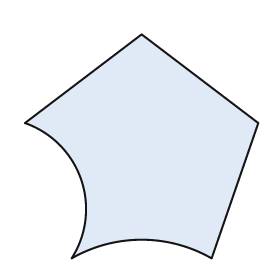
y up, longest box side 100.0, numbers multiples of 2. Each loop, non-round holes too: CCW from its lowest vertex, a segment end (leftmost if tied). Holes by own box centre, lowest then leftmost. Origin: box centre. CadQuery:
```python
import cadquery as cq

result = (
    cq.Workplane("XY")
    .moveTo(-30.0, -48.0)
    .threePointArc((0.0, -40.0), (30.0, -48.0))
    .lineTo(50.0, 10.0)
    .lineTo(0.0, 48.0)
    .lineTo(-50.0, 10.0)
    .threePointArc((-26.0, -14.0), (-30.0, -48.0))
    .close()
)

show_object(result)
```